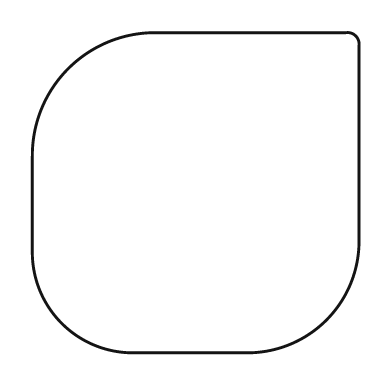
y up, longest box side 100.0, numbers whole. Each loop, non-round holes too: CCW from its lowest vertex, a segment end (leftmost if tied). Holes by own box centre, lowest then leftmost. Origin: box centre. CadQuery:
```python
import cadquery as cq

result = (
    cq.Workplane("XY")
    .moveTo(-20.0, -49.0)
    .lineTo(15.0, -49.0)
    .threePointArc((40.0, -39.0), (50.0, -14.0))
    .lineTo(50.0, 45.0)
    .threePointArc((49.0, 48.0), (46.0, 49.0))
    .lineTo(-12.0, 49.0)
    .threePointArc((-39.0, 38.0), (-50.0, 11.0))
    .lineTo(-50.0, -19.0)
    .threePointArc((-41.0, -40.0), (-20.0, -49.0))
    .close()
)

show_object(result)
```